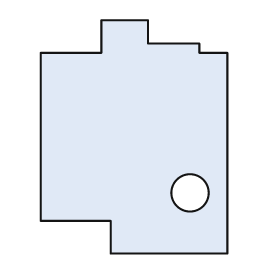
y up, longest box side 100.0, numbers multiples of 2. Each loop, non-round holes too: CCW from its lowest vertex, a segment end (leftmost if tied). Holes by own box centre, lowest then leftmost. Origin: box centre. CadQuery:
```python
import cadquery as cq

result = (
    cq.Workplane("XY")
    .moveTo(-10.0, -50.0)
    .lineTo(40.0, -50.0)
    .lineTo(40.0, 36.0)
    .lineTo(28.0, 36.0)
    .lineTo(28.0, 40.0)
    .lineTo(6.0, 40.0)
    .lineTo(6.0, 50.0)
    .lineTo(-14.0, 50.0)
    .lineTo(-14.0, 36.0)
    .lineTo(-40.0, 36.0)
    .lineTo(-40.0, -36.0)
    .lineTo(-10.0, -36.0)
    .close()
    .moveTo(24.0, -24.0)
    .circle(8.0)
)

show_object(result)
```